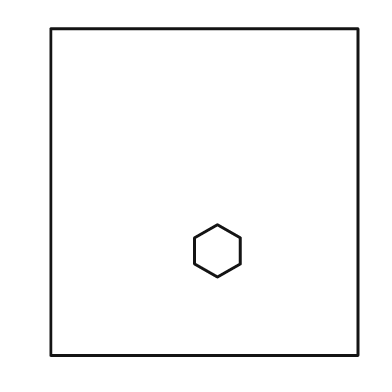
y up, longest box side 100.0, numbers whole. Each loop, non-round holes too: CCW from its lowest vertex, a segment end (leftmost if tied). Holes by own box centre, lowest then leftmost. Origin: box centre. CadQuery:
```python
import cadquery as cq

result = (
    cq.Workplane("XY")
    .moveTo(-47.0, -50.0)
    .lineTo(47.0, -50.0)
    .lineTo(47.0, 50.0)
    .lineTo(-47.0, 50.0)
    .close()
    .moveTo(4.0, -26.0)
    .lineTo(11.0, -22.0)
    .lineTo(11.0, -14.0)
    .lineTo(4.0, -10.0)
    .lineTo(-3.0, -14.0)
    .lineTo(-3.0, -22.0)
    .close()
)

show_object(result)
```